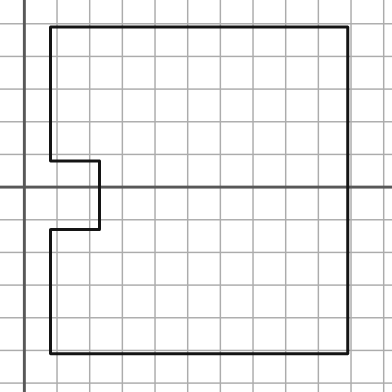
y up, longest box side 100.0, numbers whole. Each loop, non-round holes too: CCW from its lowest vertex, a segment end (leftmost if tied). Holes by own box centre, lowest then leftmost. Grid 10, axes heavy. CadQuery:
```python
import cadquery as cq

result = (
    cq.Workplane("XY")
    .moveTo(8.0, -51.0)
    .lineTo(99.0, -51.0)
    .lineTo(99.0, 49.0)
    .lineTo(8.0, 49.0)
    .lineTo(8.0, 8.0)
    .lineTo(23.0, 8.0)
    .lineTo(23.0, -13.0)
    .lineTo(8.0, -13.0)
    .close()
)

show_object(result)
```